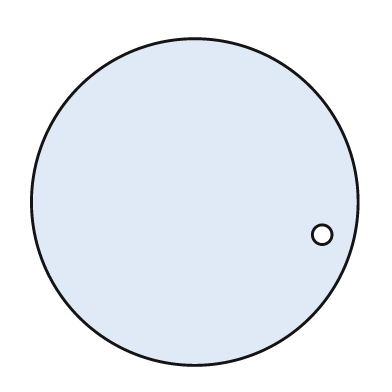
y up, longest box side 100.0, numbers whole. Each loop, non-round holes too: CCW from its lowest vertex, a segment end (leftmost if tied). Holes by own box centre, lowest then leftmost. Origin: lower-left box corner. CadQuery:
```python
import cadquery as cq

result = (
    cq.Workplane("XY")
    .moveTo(50.0, 50.0)
    .circle(50.0)
    .moveTo(89.0, 40.0)
    .circle(3.0)
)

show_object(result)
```